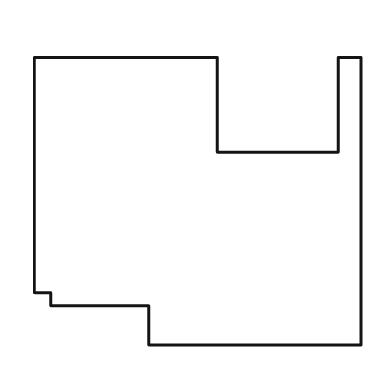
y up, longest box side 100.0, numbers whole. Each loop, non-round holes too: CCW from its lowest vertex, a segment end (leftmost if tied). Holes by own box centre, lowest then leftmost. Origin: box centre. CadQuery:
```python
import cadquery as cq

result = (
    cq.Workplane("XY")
    .moveTo(-15.0, -44.0)
    .lineTo(50.0, -44.0)
    .lineTo(50.0, 44.0)
    .lineTo(43.0, 44.0)
    .lineTo(43.0, 15.0)
    .lineTo(6.0, 15.0)
    .lineTo(6.0, 44.0)
    .lineTo(-50.0, 44.0)
    .lineTo(-50.0, -28.0)
    .lineTo(-45.0, -28.0)
    .lineTo(-45.0, -32.0)
    .lineTo(-15.0, -32.0)
    .close()
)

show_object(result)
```